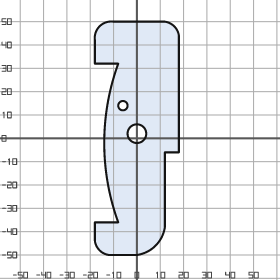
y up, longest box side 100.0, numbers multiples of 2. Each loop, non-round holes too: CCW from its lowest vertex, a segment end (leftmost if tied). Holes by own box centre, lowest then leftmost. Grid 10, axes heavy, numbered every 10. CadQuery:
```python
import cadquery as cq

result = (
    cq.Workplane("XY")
    .moveTo(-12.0, -50.0)
    .lineTo(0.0, -50.0)
    .threePointArc((8.0, -46.0), (12.0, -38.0))
    .lineTo(12.0, -6.0)
    .lineTo(18.0, -6.0)
    .lineTo(18.0, 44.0)
    .threePointArc((16.0, 48.0), (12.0, 50.0))
    .lineTo(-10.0, 50.0)
    .threePointArc((-16.0, 48.0), (-18.0, 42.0))
    .lineTo(-18.0, 32.0)
    .lineTo(-8.0, 32.0)
    .threePointArc((-14.0, -2.0), (-8.0, -36.0))
    .lineTo(-18.0, -36.0)
    .lineTo(-18.0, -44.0)
    .threePointArc((-16.0, -48.0), (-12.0, -50.0))
    .close()
    .moveTo(0.0, 2.0)
    .circle(4.0)
    .moveTo(-6.0, 14.0)
    .circle(2.0)
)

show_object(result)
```